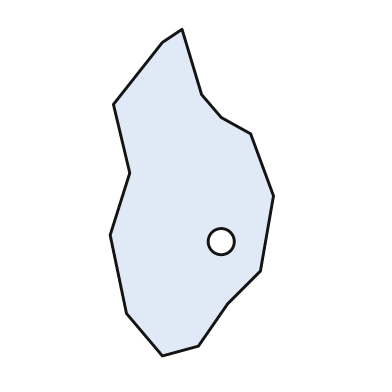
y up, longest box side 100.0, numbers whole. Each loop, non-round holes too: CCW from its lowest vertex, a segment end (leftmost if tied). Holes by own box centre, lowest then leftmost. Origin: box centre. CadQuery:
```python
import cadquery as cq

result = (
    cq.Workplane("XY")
    .moveTo(-9.0, -50.0)
    .lineTo(2.0, -47.0)
    .lineTo(11.0, -34.0)
    .lineTo(21.0, -24.0)
    .lineTo(25.0, -1.0)
    .lineTo(18.0, 18.0)
    .lineTo(9.0, 23.0)
    .lineTo(3.0, 30.0)
    .lineTo(-3.0, 50.0)
    .lineTo(-9.0, 46.0)
    .lineTo(-24.0, 27.0)
    .lineTo(-19.0, 6.0)
    .lineTo(-25.0, -13.0)
    .lineTo(-20.0, -37.0)
    .close()
    .moveTo(9.0, -15.0)
    .circle(4.0)
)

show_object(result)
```